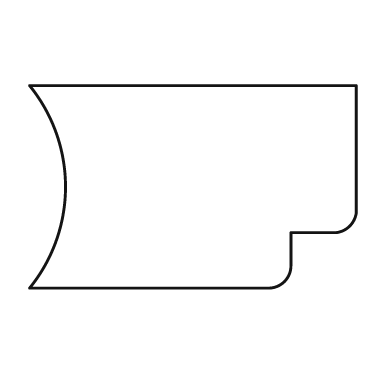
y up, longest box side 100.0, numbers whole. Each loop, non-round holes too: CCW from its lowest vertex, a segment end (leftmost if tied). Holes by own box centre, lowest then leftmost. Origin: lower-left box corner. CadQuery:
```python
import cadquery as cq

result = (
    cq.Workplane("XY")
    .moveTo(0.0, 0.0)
    .lineTo(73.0, 0.0)
    .threePointArc((78.0, 2.0), (80.0, 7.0))
    .lineTo(80.0, 17.0)
    .lineTo(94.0, 17.0)
    .threePointArc((98.0, 19.0), (100.0, 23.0))
    .lineTo(100.0, 62.0)
    .lineTo(0.0, 62.0)
    .threePointArc((11.0, 31.0), (0.0, 0.0))
    .close()
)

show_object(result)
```